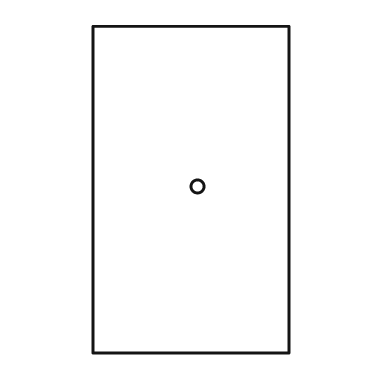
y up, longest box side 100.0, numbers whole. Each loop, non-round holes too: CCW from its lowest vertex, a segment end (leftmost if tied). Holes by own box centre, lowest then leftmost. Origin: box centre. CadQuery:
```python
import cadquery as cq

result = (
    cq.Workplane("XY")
    .moveTo(-30.0, -50.0)
    .lineTo(30.0, -50.0)
    .lineTo(30.0, 50.0)
    .lineTo(-30.0, 50.0)
    .close()
    .moveTo(2.0, 1.0)
    .circle(2.0)
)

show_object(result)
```